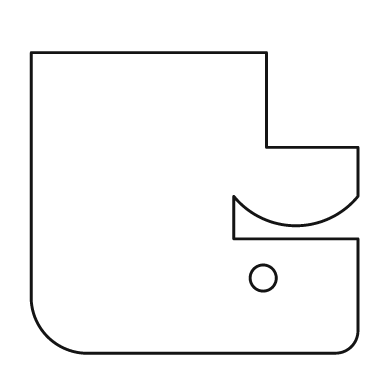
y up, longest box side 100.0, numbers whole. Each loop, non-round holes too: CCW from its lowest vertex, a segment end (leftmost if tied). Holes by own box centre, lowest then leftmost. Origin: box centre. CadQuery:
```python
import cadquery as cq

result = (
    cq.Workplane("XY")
    .moveTo(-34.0, -46.0)
    .lineTo(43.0, -46.0)
    .threePointArc((48.0, -44.0), (50.0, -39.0))
    .lineTo(50.0, -11.0)
    .lineTo(12.0, -11.0)
    .lineTo(12.0, 2.0)
    .threePointArc((31.0, -7.0), (50.0, 2.0))
    .lineTo(50.0, 17.0)
    .lineTo(22.0, 17.0)
    .lineTo(22.0, 46.0)
    .lineTo(-50.0, 46.0)
    .lineTo(-50.0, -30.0)
    .threePointArc((-45.0, -41.0), (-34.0, -46.0))
    .close()
    .moveTo(21.0, -23.0)
    .circle(4.0)
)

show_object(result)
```